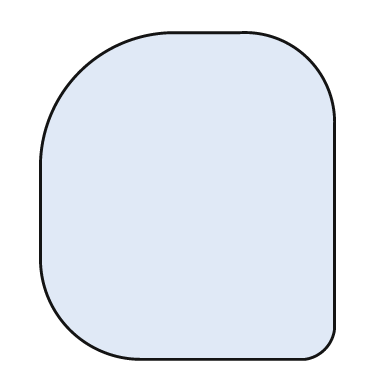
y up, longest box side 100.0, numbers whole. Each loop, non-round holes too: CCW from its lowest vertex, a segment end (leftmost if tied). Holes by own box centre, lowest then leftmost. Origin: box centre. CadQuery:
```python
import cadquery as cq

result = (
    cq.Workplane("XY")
    .moveTo(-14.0, -50.0)
    .lineTo(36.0, -50.0)
    .threePointArc((42.0, -47.0), (45.0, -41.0))
    .lineTo(45.0, 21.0)
    .threePointArc((37.0, 42.0), (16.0, 50.0))
    .lineTo(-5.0, 50.0)
    .threePointArc((-33.0, 38.0), (-45.0, 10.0))
    .lineTo(-45.0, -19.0)
    .threePointArc((-36.0, -41.0), (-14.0, -50.0))
    .close()
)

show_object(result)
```